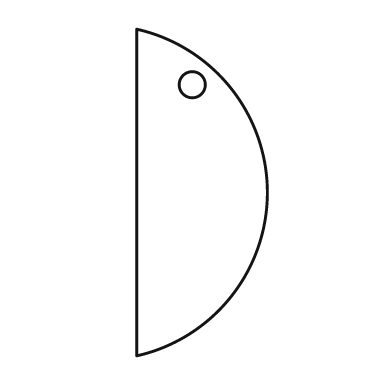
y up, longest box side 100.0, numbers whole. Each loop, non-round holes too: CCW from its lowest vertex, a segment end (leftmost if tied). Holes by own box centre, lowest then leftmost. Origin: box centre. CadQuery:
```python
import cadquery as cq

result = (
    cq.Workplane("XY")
    .moveTo(-20.0, -50.0)
    .threePointArc((20.0, 0.0), (-20.0, 50.0))
    .close()
    .moveTo(-3.0, 33.0)
    .circle(4.0)
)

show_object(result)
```